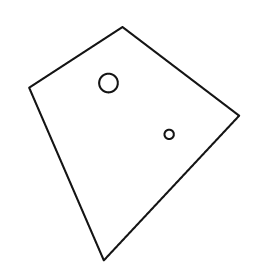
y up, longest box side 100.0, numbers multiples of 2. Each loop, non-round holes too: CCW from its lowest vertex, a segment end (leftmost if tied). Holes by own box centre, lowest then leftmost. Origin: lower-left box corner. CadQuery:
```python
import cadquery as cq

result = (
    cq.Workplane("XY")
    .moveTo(32.0, 0.0)
    .lineTo(90.0, 62.0)
    .lineTo(40.0, 100.0)
    .lineTo(0.0, 74.0)
    .close()
    .moveTo(60.0, 54.0)
    .circle(2.0)
    .moveTo(34.0, 76.0)
    .circle(4.0)
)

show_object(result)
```